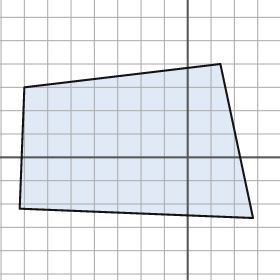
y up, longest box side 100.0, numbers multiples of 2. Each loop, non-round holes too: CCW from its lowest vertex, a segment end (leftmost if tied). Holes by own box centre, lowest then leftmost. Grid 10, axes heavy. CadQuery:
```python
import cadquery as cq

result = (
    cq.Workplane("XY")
    .moveTo(28.0, -26.0)
    .lineTo(14.0, 40.0)
    .lineTo(-70.0, 30.0)
    .lineTo(-72.0, -22.0)
    .close()
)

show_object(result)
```